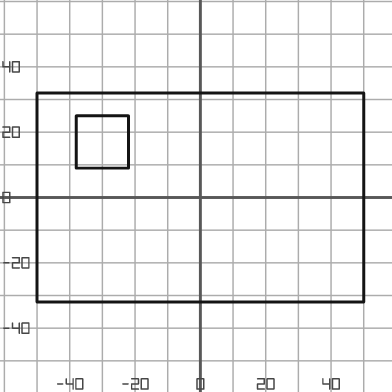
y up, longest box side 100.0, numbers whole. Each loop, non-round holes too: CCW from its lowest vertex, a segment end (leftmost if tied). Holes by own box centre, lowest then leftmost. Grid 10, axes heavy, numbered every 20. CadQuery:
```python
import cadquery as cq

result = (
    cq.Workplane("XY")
    .moveTo(-50.0, -32.0)
    .lineTo(50.0, -32.0)
    .lineTo(50.0, 32.0)
    .lineTo(-50.0, 32.0)
    .close()
    .moveTo(-38.0, 9.0)
    .lineTo(-22.0, 9.0)
    .lineTo(-22.0, 25.0)
    .lineTo(-38.0, 25.0)
    .close()
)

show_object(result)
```